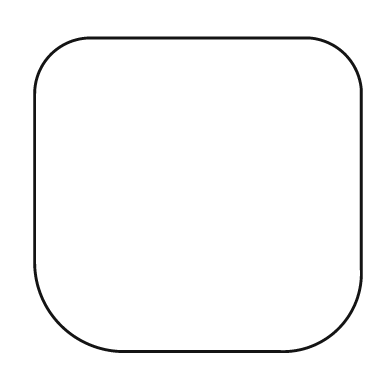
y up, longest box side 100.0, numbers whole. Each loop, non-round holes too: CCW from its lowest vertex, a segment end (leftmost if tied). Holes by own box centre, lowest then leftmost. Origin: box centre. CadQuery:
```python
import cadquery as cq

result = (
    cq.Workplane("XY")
    .moveTo(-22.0, -48.0)
    .lineTo(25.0, -48.0)
    .threePointArc((43.0, -41.0), (50.0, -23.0))
    .lineTo(50.0, 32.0)
    .threePointArc((45.0, 43.0), (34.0, 48.0))
    .lineTo(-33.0, 48.0)
    .threePointArc((-45.0, 43.0), (-50.0, 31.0))
    .lineTo(-50.0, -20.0)
    .threePointArc((-42.0, -40.0), (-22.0, -48.0))
    .close()
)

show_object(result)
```